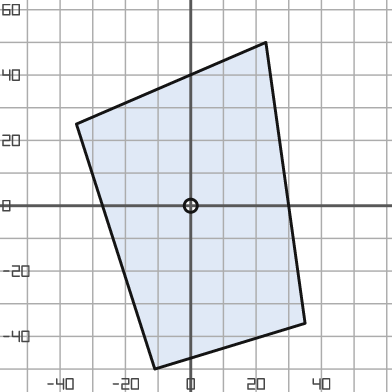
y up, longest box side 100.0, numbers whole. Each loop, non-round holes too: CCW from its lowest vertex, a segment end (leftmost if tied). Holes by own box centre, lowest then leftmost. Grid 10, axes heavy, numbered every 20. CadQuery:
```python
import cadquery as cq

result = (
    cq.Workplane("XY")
    .moveTo(-11.0, -50.0)
    .lineTo(35.0, -36.0)
    .lineTo(23.0, 50.0)
    .lineTo(-35.0, 25.0)
    .close()
    .moveTo(0.0, 0.0)
    .circle(2.0)
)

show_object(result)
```